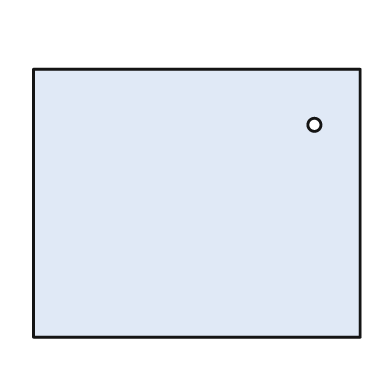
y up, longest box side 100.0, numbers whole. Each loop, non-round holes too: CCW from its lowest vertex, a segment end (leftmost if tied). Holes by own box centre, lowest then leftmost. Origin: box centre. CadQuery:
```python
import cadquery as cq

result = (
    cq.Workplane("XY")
    .moveTo(-50.0, -41.0)
    .lineTo(50.0, -41.0)
    .lineTo(50.0, 41.0)
    .lineTo(-50.0, 41.0)
    .close()
    .moveTo(36.0, 24.0)
    .circle(2.0)
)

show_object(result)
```